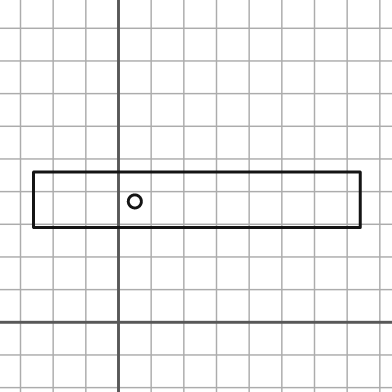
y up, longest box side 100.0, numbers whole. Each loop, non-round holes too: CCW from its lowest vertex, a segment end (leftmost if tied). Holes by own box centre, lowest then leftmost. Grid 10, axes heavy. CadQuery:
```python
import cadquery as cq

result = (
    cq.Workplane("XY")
    .moveTo(-26.0, 29.0)
    .lineTo(74.0, 29.0)
    .lineTo(74.0, 46.0)
    .lineTo(-26.0, 46.0)
    .close()
    .moveTo(5.0, 37.0)
    .circle(2.0)
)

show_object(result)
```